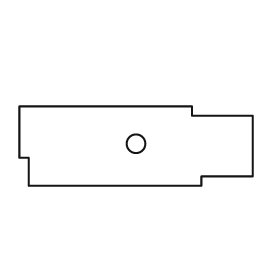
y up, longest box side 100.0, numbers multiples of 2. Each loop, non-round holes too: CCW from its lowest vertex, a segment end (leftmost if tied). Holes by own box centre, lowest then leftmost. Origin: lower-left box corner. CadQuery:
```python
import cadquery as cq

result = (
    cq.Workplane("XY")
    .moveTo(4.0, 0.0)
    .lineTo(78.0, 0.0)
    .lineTo(78.0, 4.0)
    .lineTo(100.0, 4.0)
    .lineTo(100.0, 30.0)
    .lineTo(74.0, 30.0)
    .lineTo(74.0, 34.0)
    .lineTo(0.0, 34.0)
    .lineTo(0.0, 12.0)
    .lineTo(4.0, 12.0)
    .close()
    .moveTo(50.0, 18.0)
    .circle(4.0)
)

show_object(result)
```